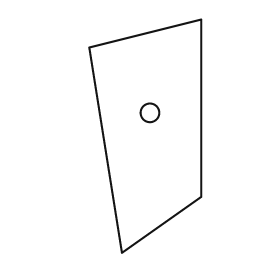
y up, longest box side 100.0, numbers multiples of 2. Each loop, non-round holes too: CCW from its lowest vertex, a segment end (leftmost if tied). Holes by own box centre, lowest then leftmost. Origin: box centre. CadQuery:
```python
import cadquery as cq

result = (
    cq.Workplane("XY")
    .moveTo(-10.0, -50.0)
    .lineTo(24.0, -26.0)
    .lineTo(24.0, 50.0)
    .lineTo(-24.0, 38.0)
    .close()
    .moveTo(2.0, 10.0)
    .circle(4.0)
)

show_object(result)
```